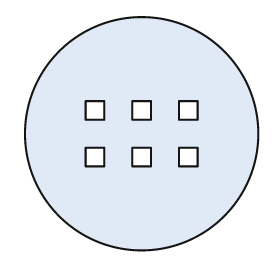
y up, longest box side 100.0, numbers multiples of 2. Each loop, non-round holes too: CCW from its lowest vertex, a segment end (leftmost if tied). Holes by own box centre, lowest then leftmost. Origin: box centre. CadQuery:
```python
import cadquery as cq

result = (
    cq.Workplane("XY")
    .moveTo(0.0, 0.0)
    .circle(50.0)
    .moveTo(-24.0, -14.0)
    .lineTo(-16.0, -14.0)
    .lineTo(-16.0, -6.0)
    .lineTo(-24.0, -6.0)
    .close()
    .moveTo(-4.0, -14.0)
    .lineTo(4.0, -14.0)
    .lineTo(4.0, -6.0)
    .lineTo(-4.0, -6.0)
    .close()
    .moveTo(16.0, -14.0)
    .lineTo(24.0, -14.0)
    .lineTo(24.0, -6.0)
    .lineTo(16.0, -6.0)
    .close()
    .moveTo(-24.0, 6.0)
    .lineTo(-16.0, 6.0)
    .lineTo(-16.0, 14.0)
    .lineTo(-24.0, 14.0)
    .close()
    .moveTo(-4.0, 6.0)
    .lineTo(4.0, 6.0)
    .lineTo(4.0, 14.0)
    .lineTo(-4.0, 14.0)
    .close()
    .moveTo(16.0, 6.0)
    .lineTo(24.0, 6.0)
    .lineTo(24.0, 14.0)
    .lineTo(16.0, 14.0)
    .close()
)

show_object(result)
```